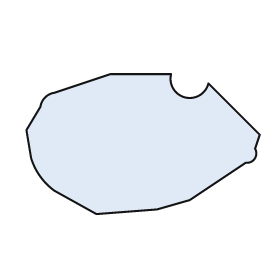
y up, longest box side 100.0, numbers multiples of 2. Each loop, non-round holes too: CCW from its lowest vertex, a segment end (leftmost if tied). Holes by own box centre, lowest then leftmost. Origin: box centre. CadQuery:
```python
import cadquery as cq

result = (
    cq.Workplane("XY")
    .moveTo(-20.0, -30.0)
    .lineTo(6.0, -28.0)
    .lineTo(20.0, -24.0)
    .lineTo(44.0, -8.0)
    .threePointArc((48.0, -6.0), (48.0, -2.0))
    .lineTo(50.0, 4.0)
    .lineTo(28.0, 26.0)
    .threePointArc((18.0, 20.0), (12.0, 30.0))
    .lineTo(-14.0, 30.0)
    .lineTo(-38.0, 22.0)
    .threePointArc((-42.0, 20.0), (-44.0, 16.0))
    .lineTo(-50.0, 6.0)
    .lineTo(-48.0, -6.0)
    .threePointArc((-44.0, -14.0), (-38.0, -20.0))
    .close()
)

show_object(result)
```